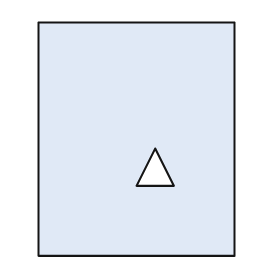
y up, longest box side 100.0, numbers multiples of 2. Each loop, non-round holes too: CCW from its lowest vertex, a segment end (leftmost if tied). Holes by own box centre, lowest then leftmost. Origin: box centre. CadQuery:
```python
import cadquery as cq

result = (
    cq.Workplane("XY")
    .moveTo(-42.0, -50.0)
    .lineTo(42.0, -50.0)
    .lineTo(42.0, 50.0)
    .lineTo(-42.0, 50.0)
    .close()
    .moveTo(0.0, -20.0)
    .lineTo(16.0, -20.0)
    .lineTo(8.0, -4.0)
    .close()
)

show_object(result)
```